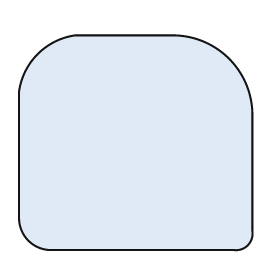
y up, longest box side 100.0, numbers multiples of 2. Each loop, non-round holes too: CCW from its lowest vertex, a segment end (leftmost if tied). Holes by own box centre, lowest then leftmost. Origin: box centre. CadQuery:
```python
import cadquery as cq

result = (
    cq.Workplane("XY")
    .moveTo(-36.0, -46.0)
    .lineTo(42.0, -46.0)
    .threePointArc((48.0, -44.0), (50.0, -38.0))
    .lineTo(50.0, 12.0)
    .threePointArc((40.0, 36.0), (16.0, 46.0))
    .lineTo(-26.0, 46.0)
    .threePointArc((-42.0, 38.0), (-50.0, 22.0))
    .lineTo(-50.0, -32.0)
    .threePointArc((-46.0, -42.0), (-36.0, -46.0))
    .close()
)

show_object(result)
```